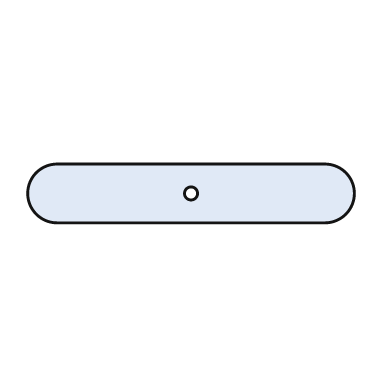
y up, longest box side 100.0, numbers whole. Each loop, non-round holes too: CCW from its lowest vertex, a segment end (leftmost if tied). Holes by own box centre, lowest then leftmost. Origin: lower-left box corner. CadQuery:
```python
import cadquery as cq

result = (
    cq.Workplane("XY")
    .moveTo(9.0, 0.0)
    .lineTo(91.0, 0.0)
    .threePointArc((100.0, 9.0), (91.0, 18.0))
    .lineTo(9.0, 18.0)
    .threePointArc((0.0, 9.0), (9.0, 0.0))
    .close()
    .moveTo(50.0, 9.0)
    .circle(2.0)
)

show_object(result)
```